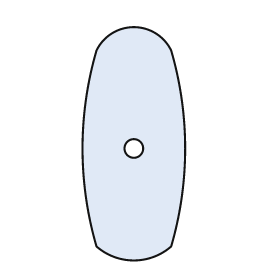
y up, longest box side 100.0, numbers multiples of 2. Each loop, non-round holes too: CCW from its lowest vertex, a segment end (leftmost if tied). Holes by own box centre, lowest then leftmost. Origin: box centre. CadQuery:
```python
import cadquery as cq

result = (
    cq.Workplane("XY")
    .moveTo(-16.0, -44.0)
    .threePointArc((0.0, -50.0), (16.0, -44.0))
    .threePointArc((22.0, -2.0), (16.0, 40.0))
    .threePointArc((0.0, 50.0), (-16.0, 40.0))
    .threePointArc((-22.0, -2.0), (-16.0, -44.0))
    .close()
    .moveTo(0.0, -2.0)
    .circle(4.0)
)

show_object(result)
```